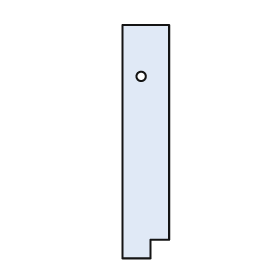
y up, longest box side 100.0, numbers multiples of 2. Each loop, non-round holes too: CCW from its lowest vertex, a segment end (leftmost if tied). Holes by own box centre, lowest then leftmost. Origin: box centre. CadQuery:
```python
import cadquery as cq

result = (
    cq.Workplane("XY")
    .moveTo(-10.0, -50.0)
    .lineTo(2.0, -50.0)
    .lineTo(2.0, -42.0)
    .lineTo(10.0, -42.0)
    .lineTo(10.0, 50.0)
    .lineTo(-10.0, 50.0)
    .close()
    .moveTo(-2.0, 28.0)
    .circle(2.0)
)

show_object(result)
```